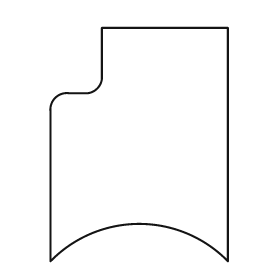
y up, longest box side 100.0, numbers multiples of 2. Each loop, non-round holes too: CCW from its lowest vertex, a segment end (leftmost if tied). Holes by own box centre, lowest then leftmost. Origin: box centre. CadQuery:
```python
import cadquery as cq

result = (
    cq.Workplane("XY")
    .moveTo(-38.0, -50.0)
    .threePointArc((0.0, -34.0), (38.0, -50.0))
    .lineTo(38.0, 50.0)
    .lineTo(-16.0, 50.0)
    .lineTo(-16.0, 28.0)
    .threePointArc((-18.0, 24.0), (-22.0, 22.0))
    .lineTo(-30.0, 22.0)
    .threePointArc((-36.0, 20.0), (-38.0, 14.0))
    .close()
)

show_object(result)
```